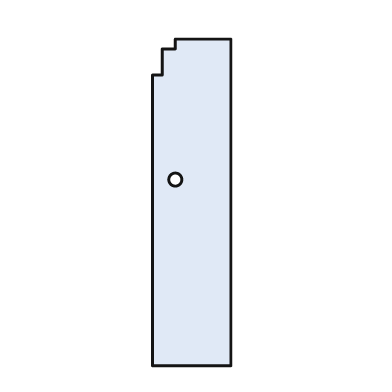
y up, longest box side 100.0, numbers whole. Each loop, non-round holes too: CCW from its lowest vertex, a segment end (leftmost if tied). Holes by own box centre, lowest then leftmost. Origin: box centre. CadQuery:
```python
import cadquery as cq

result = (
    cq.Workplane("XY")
    .moveTo(-12.0, -50.0)
    .lineTo(12.0, -50.0)
    .lineTo(12.0, 50.0)
    .lineTo(-5.0, 50.0)
    .lineTo(-5.0, 47.0)
    .lineTo(-9.0, 47.0)
    .lineTo(-9.0, 39.0)
    .lineTo(-12.0, 39.0)
    .close()
    .moveTo(-5.0, 7.0)
    .circle(2.0)
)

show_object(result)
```